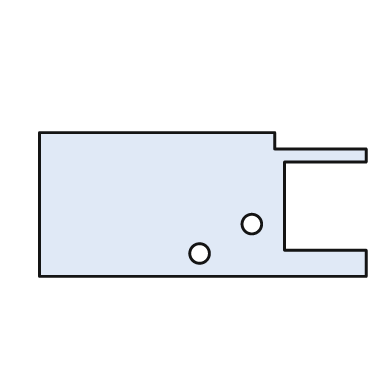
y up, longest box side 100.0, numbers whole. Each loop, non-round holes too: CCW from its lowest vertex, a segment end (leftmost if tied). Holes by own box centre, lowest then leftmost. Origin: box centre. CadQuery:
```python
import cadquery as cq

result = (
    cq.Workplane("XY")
    .moveTo(-50.0, -22.0)
    .lineTo(50.0, -22.0)
    .lineTo(50.0, -14.0)
    .lineTo(25.0, -14.0)
    .lineTo(25.0, 13.0)
    .lineTo(50.0, 13.0)
    .lineTo(50.0, 17.0)
    .lineTo(22.0, 17.0)
    .lineTo(22.0, 22.0)
    .lineTo(-50.0, 22.0)
    .close()
    .moveTo(-1.0, -15.0)
    .circle(3.0)
    .moveTo(15.0, -6.0)
    .circle(3.0)
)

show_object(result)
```